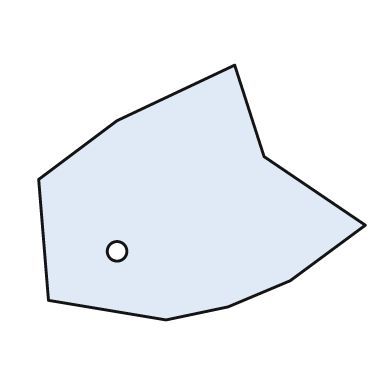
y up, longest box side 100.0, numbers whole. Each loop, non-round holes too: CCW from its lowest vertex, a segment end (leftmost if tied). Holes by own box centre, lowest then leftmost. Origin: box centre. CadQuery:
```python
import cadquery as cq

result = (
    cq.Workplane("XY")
    .moveTo(-11.0, -39.0)
    .lineTo(8.0, -35.0)
    .lineTo(27.0, -27.0)
    .lineTo(50.0, -10.0)
    .lineTo(19.0, 11.0)
    .lineTo(10.0, 39.0)
    .lineTo(-26.0, 22.0)
    .lineTo(-50.0, 4.0)
    .lineTo(-47.0, -33.0)
    .close()
    .moveTo(-26.0, -18.0)
    .circle(3.0)
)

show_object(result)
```